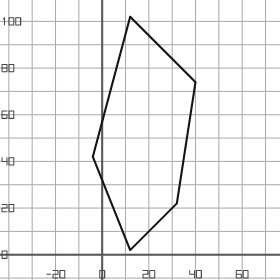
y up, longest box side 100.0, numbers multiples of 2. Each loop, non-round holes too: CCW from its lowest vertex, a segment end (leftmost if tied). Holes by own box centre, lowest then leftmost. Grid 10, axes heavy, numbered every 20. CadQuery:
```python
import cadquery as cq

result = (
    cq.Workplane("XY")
    .moveTo(12.0, 2.0)
    .lineTo(32.0, 22.0)
    .lineTo(40.0, 74.0)
    .lineTo(12.0, 102.0)
    .lineTo(-4.0, 42.0)
    .close()
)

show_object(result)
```